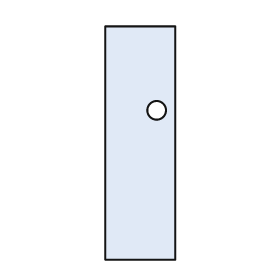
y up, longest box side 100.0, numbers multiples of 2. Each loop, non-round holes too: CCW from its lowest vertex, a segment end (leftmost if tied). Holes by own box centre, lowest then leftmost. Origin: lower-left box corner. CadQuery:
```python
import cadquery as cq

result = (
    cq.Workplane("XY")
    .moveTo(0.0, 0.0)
    .lineTo(30.0, 0.0)
    .lineTo(30.0, 100.0)
    .lineTo(0.0, 100.0)
    .close()
    .moveTo(22.0, 64.0)
    .circle(4.0)
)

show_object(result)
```